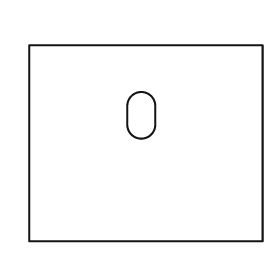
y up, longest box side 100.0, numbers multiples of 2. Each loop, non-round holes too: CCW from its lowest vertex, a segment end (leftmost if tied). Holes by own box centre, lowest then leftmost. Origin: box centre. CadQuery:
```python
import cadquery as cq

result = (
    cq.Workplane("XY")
    .moveTo(-50.0, -42.0)
    .lineTo(50.0, -42.0)
    .lineTo(50.0, 42.0)
    .lineTo(-50.0, 42.0)
    .close()
    .moveTo(-8.0, 8.0)
    .threePointArc((-2.0, 2.0), (4.0, 8.0))
    .lineTo(4.0, 16.0)
    .threePointArc((-2.0, 22.0), (-8.0, 16.0))
    .close()
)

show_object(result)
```